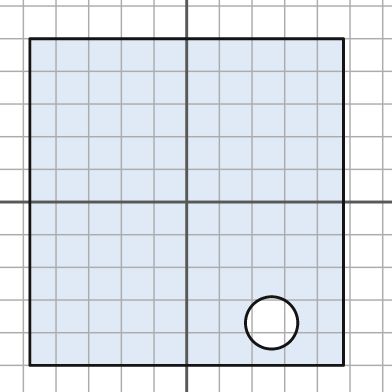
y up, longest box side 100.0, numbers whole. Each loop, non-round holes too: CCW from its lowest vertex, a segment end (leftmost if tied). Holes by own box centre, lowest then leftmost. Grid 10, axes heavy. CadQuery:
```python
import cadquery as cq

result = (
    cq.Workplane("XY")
    .moveTo(-48.0, -50.0)
    .lineTo(48.0, -50.0)
    .lineTo(48.0, 50.0)
    .lineTo(-48.0, 50.0)
    .close()
    .moveTo(26.0, -37.0)
    .circle(8.0)
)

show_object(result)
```